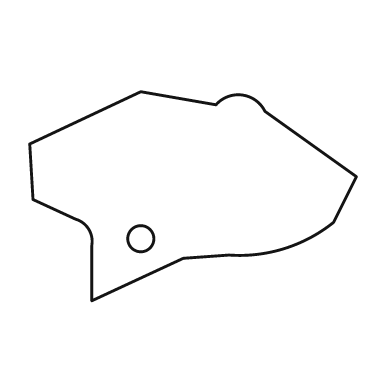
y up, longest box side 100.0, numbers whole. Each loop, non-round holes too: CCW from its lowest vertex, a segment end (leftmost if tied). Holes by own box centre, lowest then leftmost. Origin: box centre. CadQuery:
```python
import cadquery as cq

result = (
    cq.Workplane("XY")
    .moveTo(-31.0, -32.0)
    .lineTo(-3.0, -19.0)
    .lineTo(11.0, -18.0)
    .threePointArc((28.0, -16.0), (43.0, -8.0))
    .lineTo(50.0, 6.0)
    .lineTo(22.0, 26.0)
    .threePointArc((15.0, 31.0), (7.0, 28.0))
    .lineTo(-16.0, 32.0)
    .lineTo(-50.0, 16.0)
    .lineTo(-49.0, -1.0)
    .lineTo(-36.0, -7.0)
    .threePointArc((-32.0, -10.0), (-31.0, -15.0))
    .close()
    .moveTo(-16.0, -13.0)
    .circle(4.0)
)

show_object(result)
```